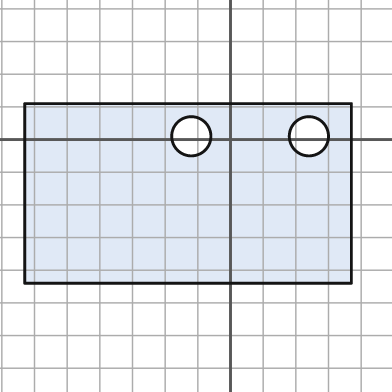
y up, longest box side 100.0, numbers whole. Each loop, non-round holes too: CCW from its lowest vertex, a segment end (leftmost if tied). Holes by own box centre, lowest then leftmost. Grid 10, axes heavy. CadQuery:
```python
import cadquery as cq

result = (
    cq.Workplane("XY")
    .moveTo(-63.0, -44.0)
    .lineTo(37.0, -44.0)
    .lineTo(37.0, 11.0)
    .lineTo(-63.0, 11.0)
    .close()
    .moveTo(-12.0, 1.0)
    .circle(6.0)
    .moveTo(24.0, 1.0)
    .circle(6.0)
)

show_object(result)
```